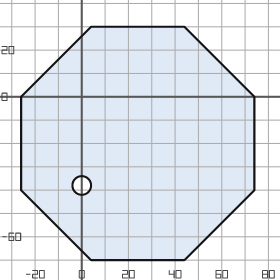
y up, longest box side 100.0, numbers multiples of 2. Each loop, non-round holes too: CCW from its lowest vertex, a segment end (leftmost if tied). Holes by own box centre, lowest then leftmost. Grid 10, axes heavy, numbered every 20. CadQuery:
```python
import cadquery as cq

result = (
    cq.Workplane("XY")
    .moveTo(4.0, -70.0)
    .lineTo(44.0, -70.0)
    .lineTo(74.0, -40.0)
    .lineTo(74.0, 0.0)
    .lineTo(44.0, 30.0)
    .lineTo(4.0, 30.0)
    .lineTo(-26.0, 0.0)
    .lineTo(-26.0, -40.0)
    .close()
    .moveTo(0.0, -38.0)
    .circle(4.0)
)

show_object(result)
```